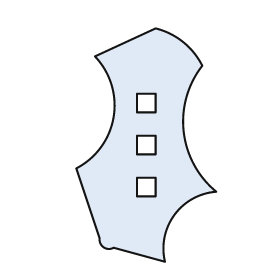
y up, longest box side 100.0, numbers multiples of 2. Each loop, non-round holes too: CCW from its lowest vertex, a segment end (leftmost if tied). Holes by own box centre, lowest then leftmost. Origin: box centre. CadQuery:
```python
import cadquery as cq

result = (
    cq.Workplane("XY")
    .moveTo(8.0, -50.0)
    .threePointArc((12.0, -30.0), (30.0, -20.0))
    .threePointArc((16.0, 6.0), (24.0, 34.0))
    .threePointArc((16.0, 44.0), (4.0, 50.0))
    .lineTo(-22.0, 38.0)
    .threePointArc((-14.0, 12.0), (-30.0, -10.0))
    .lineTo(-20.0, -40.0)
    .threePointArc((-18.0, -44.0), (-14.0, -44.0))
    .close()
    .moveTo(-4.0, -22.0)
    .lineTo(4.0, -22.0)
    .lineTo(4.0, -14.0)
    .lineTo(-4.0, -14.0)
    .close()
    .moveTo(-4.0, -4.0)
    .lineTo(4.0, -4.0)
    .lineTo(4.0, 4.0)
    .lineTo(-4.0, 4.0)
    .close()
    .moveTo(-4.0, 14.0)
    .lineTo(4.0, 14.0)
    .lineTo(4.0, 22.0)
    .lineTo(-4.0, 22.0)
    .close()
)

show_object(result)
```